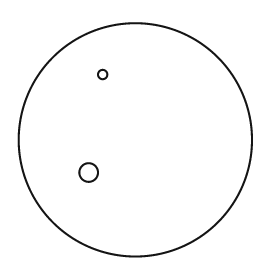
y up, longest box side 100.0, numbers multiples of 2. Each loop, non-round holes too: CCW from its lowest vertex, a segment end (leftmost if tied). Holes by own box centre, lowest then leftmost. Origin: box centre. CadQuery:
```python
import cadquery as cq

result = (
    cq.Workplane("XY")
    .moveTo(0.0, 0.0)
    .circle(50.0)
    .moveTo(-20.0, -14.0)
    .circle(4.0)
    .moveTo(-14.0, 28.0)
    .circle(2.0)
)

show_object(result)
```